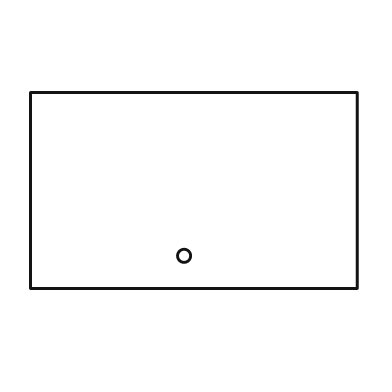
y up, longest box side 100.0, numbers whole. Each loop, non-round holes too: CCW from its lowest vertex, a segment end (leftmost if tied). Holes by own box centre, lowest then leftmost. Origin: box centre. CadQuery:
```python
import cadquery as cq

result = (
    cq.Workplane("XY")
    .moveTo(-50.0, -30.0)
    .lineTo(50.0, -30.0)
    .lineTo(50.0, 30.0)
    .lineTo(-50.0, 30.0)
    .close()
    .moveTo(-3.0, -20.0)
    .circle(2.0)
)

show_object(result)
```